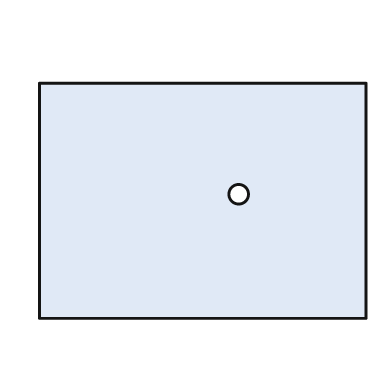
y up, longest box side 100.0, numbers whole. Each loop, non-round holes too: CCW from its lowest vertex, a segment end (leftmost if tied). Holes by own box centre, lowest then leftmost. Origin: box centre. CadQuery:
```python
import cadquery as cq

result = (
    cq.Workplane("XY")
    .moveTo(-50.0, -36.0)
    .lineTo(50.0, -36.0)
    .lineTo(50.0, 36.0)
    .lineTo(-50.0, 36.0)
    .close()
    .moveTo(11.0, 2.0)
    .circle(3.0)
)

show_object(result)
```